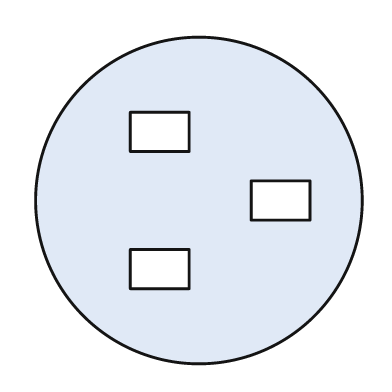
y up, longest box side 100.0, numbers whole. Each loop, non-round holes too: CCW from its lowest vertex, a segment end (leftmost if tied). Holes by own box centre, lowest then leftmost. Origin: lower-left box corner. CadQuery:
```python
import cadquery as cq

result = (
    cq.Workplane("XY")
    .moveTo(50.0, 50.0)
    .circle(50.0)
    .moveTo(29.0, 23.0)
    .lineTo(47.0, 23.0)
    .lineTo(47.0, 35.0)
    .lineTo(29.0, 35.0)
    .close()
    .moveTo(66.0, 44.0)
    .lineTo(84.0, 44.0)
    .lineTo(84.0, 56.0)
    .lineTo(66.0, 56.0)
    .close()
    .moveTo(29.0, 65.0)
    .lineTo(47.0, 65.0)
    .lineTo(47.0, 77.0)
    .lineTo(29.0, 77.0)
    .close()
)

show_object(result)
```